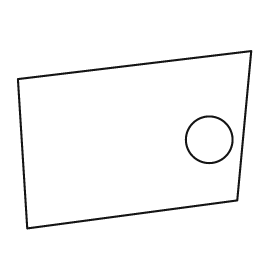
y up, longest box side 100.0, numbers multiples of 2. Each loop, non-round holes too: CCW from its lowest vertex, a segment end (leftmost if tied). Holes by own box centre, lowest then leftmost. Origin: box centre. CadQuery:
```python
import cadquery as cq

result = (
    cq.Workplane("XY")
    .moveTo(-46.0, -38.0)
    .lineTo(44.0, -26.0)
    .lineTo(50.0, 38.0)
    .lineTo(-50.0, 26.0)
    .close()
    .moveTo(32.0, 0.0)
    .circle(10.0)
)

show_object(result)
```